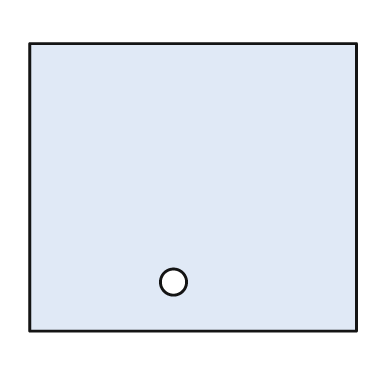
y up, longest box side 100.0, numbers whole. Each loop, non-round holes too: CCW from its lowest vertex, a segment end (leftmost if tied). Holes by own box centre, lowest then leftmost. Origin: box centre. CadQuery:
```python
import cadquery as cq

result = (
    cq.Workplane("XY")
    .moveTo(-50.0, -44.0)
    .lineTo(50.0, -44.0)
    .lineTo(50.0, 44.0)
    .lineTo(-50.0, 44.0)
    .close()
    .moveTo(-6.0, -29.0)
    .circle(4.0)
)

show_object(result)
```